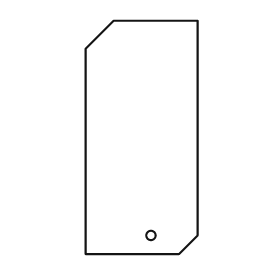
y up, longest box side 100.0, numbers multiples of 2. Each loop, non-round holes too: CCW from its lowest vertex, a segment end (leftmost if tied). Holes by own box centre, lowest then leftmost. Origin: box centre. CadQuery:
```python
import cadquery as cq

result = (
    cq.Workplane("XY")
    .moveTo(-24.0, -50.0)
    .lineTo(16.0, -50.0)
    .lineTo(24.0, -42.0)
    .lineTo(24.0, 50.0)
    .lineTo(-12.0, 50.0)
    .lineTo(-24.0, 38.0)
    .close()
    .moveTo(4.0, -42.0)
    .circle(2.0)
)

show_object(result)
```